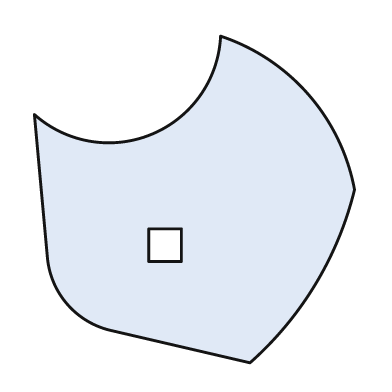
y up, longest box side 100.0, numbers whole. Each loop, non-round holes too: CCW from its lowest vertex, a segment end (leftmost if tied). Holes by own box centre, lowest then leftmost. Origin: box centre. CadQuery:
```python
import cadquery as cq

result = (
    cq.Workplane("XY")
    .moveTo(17.0, -50.0)
    .threePointArc((37.0, -26.0), (49.0, 3.0))
    .threePointArc((35.0, 32.0), (8.0, 50.0))
    .threePointArc((-13.0, 20.0), (-49.0, 26.0))
    .lineTo(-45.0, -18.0)
    .threePointArc((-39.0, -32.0), (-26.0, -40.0))
    .close()
    .moveTo(-14.0, -19.0)
    .lineTo(-4.0, -19.0)
    .lineTo(-4.0, -9.0)
    .lineTo(-14.0, -9.0)
    .close()
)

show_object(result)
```